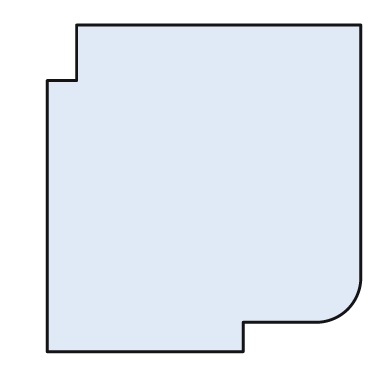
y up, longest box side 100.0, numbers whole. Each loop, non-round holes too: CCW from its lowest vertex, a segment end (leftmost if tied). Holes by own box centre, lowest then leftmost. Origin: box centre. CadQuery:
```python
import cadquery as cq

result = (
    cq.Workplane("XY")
    .moveTo(-48.0, -50.0)
    .lineTo(12.0, -50.0)
    .lineTo(12.0, -41.0)
    .lineTo(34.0, -41.0)
    .threePointArc((44.0, -37.0), (48.0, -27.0))
    .lineTo(48.0, 50.0)
    .lineTo(-39.0, 50.0)
    .lineTo(-39.0, 33.0)
    .lineTo(-48.0, 33.0)
    .close()
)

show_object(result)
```